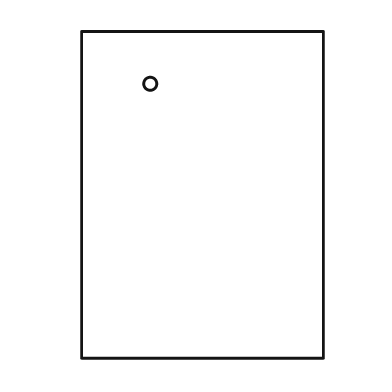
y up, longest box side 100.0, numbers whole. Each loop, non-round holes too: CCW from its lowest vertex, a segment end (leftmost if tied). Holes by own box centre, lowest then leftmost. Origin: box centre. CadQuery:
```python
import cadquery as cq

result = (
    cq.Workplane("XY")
    .moveTo(-37.0, -50.0)
    .lineTo(37.0, -50.0)
    .lineTo(37.0, 50.0)
    .lineTo(-37.0, 50.0)
    .close()
    .moveTo(-16.0, 34.0)
    .circle(2.0)
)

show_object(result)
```